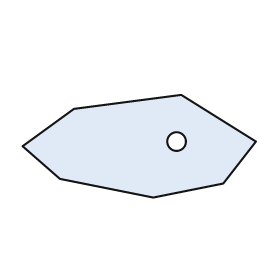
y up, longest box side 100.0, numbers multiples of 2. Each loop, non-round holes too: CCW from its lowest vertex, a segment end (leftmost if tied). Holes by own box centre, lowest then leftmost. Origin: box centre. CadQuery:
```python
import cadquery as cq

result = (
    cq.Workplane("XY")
    .moveTo(6.0, -22.0)
    .lineTo(36.0, -16.0)
    .lineTo(50.0, 2.0)
    .lineTo(18.0, 22.0)
    .lineTo(-28.0, 16.0)
    .lineTo(-50.0, 0.0)
    .lineTo(-34.0, -14.0)
    .close()
    .moveTo(16.0, 2.0)
    .circle(4.0)
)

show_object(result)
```